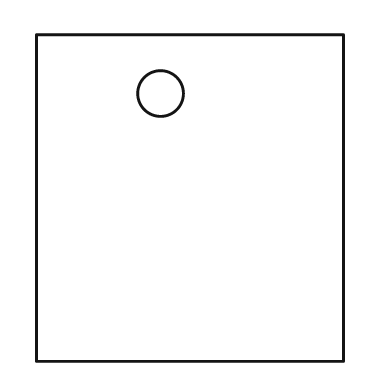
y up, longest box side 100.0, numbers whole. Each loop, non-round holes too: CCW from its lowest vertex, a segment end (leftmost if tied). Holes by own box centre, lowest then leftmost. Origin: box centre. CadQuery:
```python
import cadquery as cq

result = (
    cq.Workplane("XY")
    .moveTo(-47.0, -50.0)
    .lineTo(47.0, -50.0)
    .lineTo(47.0, 50.0)
    .lineTo(-47.0, 50.0)
    .close()
    .moveTo(-9.0, 32.0)
    .circle(7.0)
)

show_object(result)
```